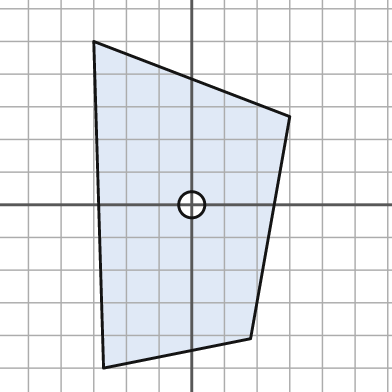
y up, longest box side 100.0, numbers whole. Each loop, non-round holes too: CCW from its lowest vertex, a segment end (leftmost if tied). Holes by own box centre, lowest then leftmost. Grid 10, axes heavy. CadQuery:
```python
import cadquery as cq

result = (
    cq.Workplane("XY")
    .moveTo(-27.0, -50.0)
    .lineTo(18.0, -41.0)
    .lineTo(30.0, 27.0)
    .lineTo(-30.0, 50.0)
    .close()
    .moveTo(0.0, 0.0)
    .circle(4.0)
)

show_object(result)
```